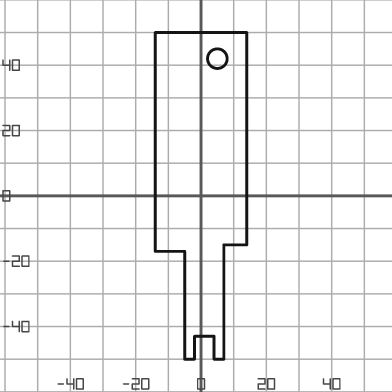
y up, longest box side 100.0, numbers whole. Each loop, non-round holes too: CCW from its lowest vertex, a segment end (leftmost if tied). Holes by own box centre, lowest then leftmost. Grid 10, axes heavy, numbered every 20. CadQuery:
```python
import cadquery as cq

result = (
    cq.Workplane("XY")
    .moveTo(-5.0, -50.0)
    .lineTo(-2.0, -50.0)
    .lineTo(-2.0, -43.0)
    .lineTo(4.0, -43.0)
    .lineTo(4.0, -50.0)
    .lineTo(7.0, -50.0)
    .lineTo(7.0, -15.0)
    .lineTo(14.0, -15.0)
    .lineTo(14.0, 50.0)
    .lineTo(-14.0, 50.0)
    .lineTo(-14.0, -17.0)
    .lineTo(-5.0, -17.0)
    .close()
    .moveTo(5.0, 42.0)
    .circle(3.0)
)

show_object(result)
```